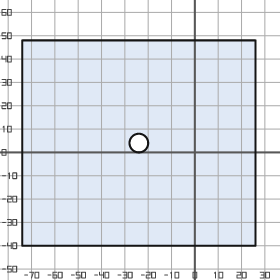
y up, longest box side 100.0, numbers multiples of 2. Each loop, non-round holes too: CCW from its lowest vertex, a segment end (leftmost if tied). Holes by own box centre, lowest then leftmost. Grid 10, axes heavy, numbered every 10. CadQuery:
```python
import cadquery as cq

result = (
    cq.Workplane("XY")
    .moveTo(-74.0, -40.0)
    .lineTo(26.0, -40.0)
    .lineTo(26.0, 48.0)
    .lineTo(-74.0, 48.0)
    .close()
    .moveTo(-24.0, 4.0)
    .circle(4.0)
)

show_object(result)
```